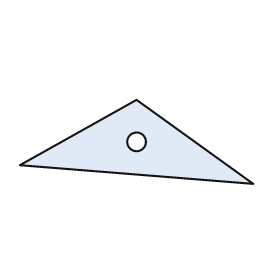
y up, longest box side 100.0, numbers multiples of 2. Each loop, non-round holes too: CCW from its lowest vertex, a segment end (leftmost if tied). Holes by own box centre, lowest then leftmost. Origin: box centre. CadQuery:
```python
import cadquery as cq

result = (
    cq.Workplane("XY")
    .moveTo(50.0, -18.0)
    .lineTo(0.0, 18.0)
    .lineTo(-50.0, -10.0)
    .close()
    .moveTo(0.0, 0.0)
    .circle(4.0)
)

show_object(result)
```